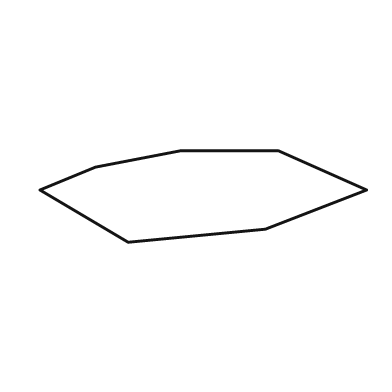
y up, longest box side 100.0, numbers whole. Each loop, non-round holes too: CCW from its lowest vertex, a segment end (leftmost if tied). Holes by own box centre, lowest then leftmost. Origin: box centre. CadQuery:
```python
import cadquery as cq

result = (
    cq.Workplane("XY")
    .moveTo(-23.0, -14.0)
    .lineTo(19.0, -10.0)
    .lineTo(50.0, 2.0)
    .lineTo(23.0, 14.0)
    .lineTo(-7.0, 14.0)
    .lineTo(-33.0, 9.0)
    .lineTo(-50.0, 2.0)
    .close()
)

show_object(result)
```